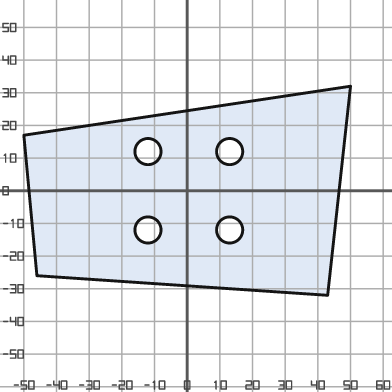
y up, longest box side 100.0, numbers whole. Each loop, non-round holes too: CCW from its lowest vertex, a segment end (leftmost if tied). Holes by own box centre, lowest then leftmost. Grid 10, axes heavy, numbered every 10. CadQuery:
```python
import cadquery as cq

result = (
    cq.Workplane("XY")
    .moveTo(43.0, -32.0)
    .lineTo(50.0, 32.0)
    .lineTo(-50.0, 17.0)
    .lineTo(-46.0, -26.0)
    .close()
    .moveTo(-12.0, -12.0)
    .circle(4.0)
    .moveTo(13.0, -12.0)
    .circle(4.0)
    .moveTo(-12.0, 12.0)
    .circle(4.0)
    .moveTo(13.0, 12.0)
    .circle(4.0)
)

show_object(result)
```